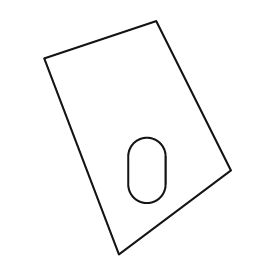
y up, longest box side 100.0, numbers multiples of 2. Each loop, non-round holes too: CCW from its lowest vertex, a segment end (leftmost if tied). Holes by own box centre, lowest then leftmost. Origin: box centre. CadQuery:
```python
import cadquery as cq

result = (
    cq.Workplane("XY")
    .moveTo(-8.0, -50.0)
    .lineTo(40.0, -14.0)
    .lineTo(8.0, 50.0)
    .lineTo(-40.0, 34.0)
    .close()
    .moveTo(-4.0, -20.0)
    .threePointArc((4.0, -28.0), (12.0, -20.0))
    .lineTo(12.0, -8.0)
    .threePointArc((4.0, 0.0), (-4.0, -8.0))
    .close()
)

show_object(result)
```